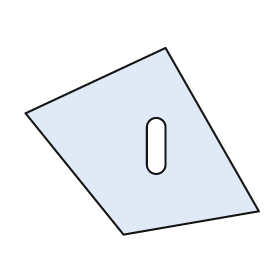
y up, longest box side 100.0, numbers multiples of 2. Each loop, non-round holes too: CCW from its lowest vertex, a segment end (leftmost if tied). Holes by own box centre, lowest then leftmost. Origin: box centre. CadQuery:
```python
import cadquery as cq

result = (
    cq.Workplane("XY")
    .moveTo(-8.0, -40.0)
    .lineTo(50.0, -30.0)
    .lineTo(10.0, 40.0)
    .lineTo(-50.0, 12.0)
    .close()
    .moveTo(2.0, -10.0)
    .threePointArc((6.0, -14.0), (10.0, -10.0))
    .lineTo(10.0, 6.0)
    .threePointArc((6.0, 10.0), (2.0, 6.0))
    .close()
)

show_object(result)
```